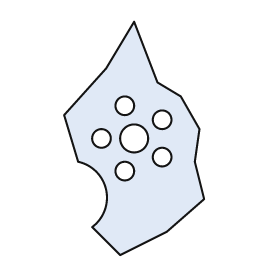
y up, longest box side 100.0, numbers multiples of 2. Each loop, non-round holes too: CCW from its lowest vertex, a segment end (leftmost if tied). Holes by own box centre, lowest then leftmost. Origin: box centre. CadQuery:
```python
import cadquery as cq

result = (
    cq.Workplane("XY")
    .moveTo(-6.0, -50.0)
    .lineTo(14.0, -40.0)
    .lineTo(30.0, -26.0)
    .lineTo(26.0, -10.0)
    .lineTo(28.0, 4.0)
    .lineTo(20.0, 18.0)
    .lineTo(10.0, 24.0)
    .lineTo(0.0, 50.0)
    .lineTo(-12.0, 30.0)
    .lineTo(-30.0, 10.0)
    .lineTo(-24.0, -10.0)
    .threePointArc((-12.0, -22.0), (-18.0, -38.0))
    .close()
    .moveTo(-4.0, -14.0)
    .circle(4.0)
    .moveTo(12.0, -8.0)
    .circle(4.0)
    .moveTo(-14.0, 0.0)
    .circle(4.0)
    .moveTo(0.0, 0.0)
    .circle(6.0)
    .moveTo(12.0, 8.0)
    .circle(4.0)
    .moveTo(-4.0, 14.0)
    .circle(4.0)
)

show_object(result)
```